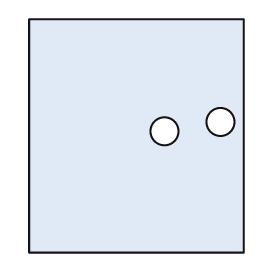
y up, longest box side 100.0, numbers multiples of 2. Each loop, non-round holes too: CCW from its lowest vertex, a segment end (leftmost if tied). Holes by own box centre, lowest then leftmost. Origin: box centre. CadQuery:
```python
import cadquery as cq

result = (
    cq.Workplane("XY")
    .moveTo(-46.0, -50.0)
    .lineTo(46.0, -50.0)
    .lineTo(46.0, 50.0)
    .lineTo(-46.0, 50.0)
    .close()
    .moveTo(12.0, 2.0)
    .circle(6.0)
    .moveTo(36.0, 6.0)
    .circle(6.0)
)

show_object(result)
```